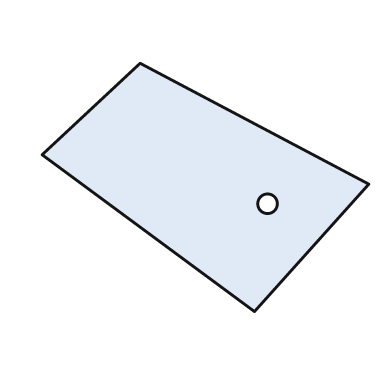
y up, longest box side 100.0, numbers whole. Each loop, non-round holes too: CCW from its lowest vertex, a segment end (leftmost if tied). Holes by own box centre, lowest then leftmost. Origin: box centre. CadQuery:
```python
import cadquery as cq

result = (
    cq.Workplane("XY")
    .moveTo(15.0, -38.0)
    .lineTo(50.0, 1.0)
    .lineTo(-20.0, 38.0)
    .lineTo(-50.0, 10.0)
    .close()
    .moveTo(19.0, -5.0)
    .circle(3.0)
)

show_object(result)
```